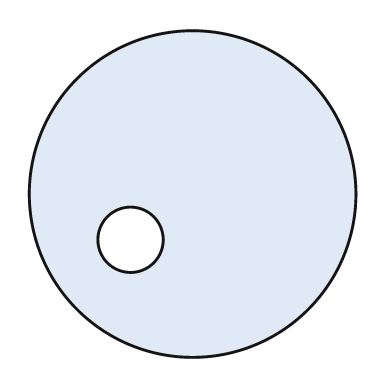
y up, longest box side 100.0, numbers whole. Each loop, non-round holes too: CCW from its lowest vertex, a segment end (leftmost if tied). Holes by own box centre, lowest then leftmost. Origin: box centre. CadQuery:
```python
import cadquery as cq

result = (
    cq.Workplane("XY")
    .moveTo(0.0, 0.0)
    .circle(50.0)
    .moveTo(-19.0, -14.0)
    .circle(10.0)
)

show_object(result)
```